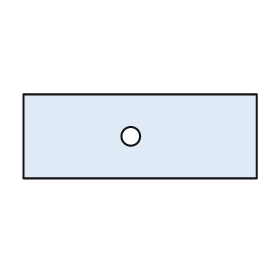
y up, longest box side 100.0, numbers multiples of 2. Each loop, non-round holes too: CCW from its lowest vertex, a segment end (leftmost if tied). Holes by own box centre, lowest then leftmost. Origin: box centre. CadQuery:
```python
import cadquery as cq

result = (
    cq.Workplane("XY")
    .moveTo(-50.0, -18.0)
    .lineTo(50.0, -18.0)
    .lineTo(50.0, 18.0)
    .lineTo(-50.0, 18.0)
    .close()
    .moveTo(-4.0, 0.0)
    .circle(4.0)
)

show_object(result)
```